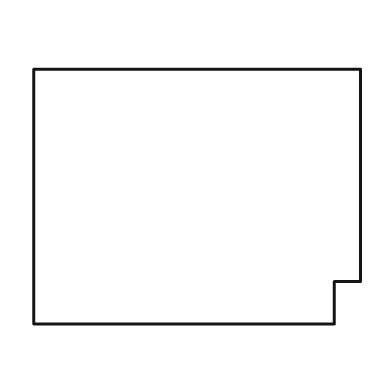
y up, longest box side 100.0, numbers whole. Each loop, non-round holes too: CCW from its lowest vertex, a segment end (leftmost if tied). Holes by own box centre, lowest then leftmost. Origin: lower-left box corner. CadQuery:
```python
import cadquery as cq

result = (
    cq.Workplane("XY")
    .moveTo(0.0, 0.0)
    .lineTo(92.0, 0.0)
    .lineTo(92.0, 13.0)
    .lineTo(100.0, 13.0)
    .lineTo(100.0, 78.0)
    .lineTo(0.0, 78.0)
    .close()
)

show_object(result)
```